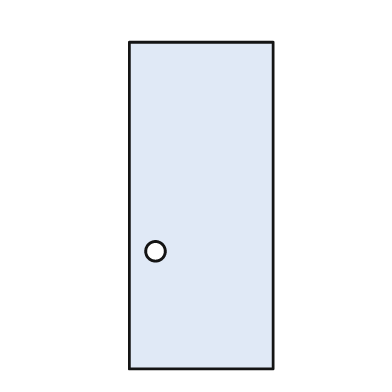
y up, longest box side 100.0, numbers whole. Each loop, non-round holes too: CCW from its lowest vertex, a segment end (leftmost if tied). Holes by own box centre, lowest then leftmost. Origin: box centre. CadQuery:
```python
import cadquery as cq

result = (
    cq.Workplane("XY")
    .moveTo(-22.0, -50.0)
    .lineTo(22.0, -50.0)
    .lineTo(22.0, 50.0)
    .lineTo(-22.0, 50.0)
    .close()
    .moveTo(-14.0, -14.0)
    .circle(3.0)
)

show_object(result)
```